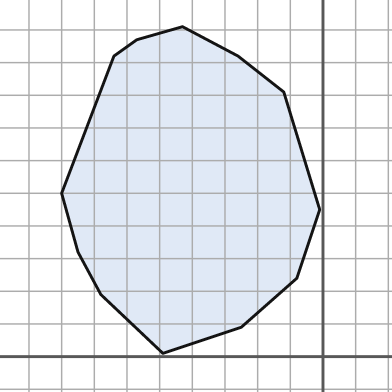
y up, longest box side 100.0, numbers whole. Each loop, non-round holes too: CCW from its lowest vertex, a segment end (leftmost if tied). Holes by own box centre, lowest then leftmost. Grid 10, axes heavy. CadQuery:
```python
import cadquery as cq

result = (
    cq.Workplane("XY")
    .moveTo(-49.0, 1.0)
    .lineTo(-25.0, 9.0)
    .lineTo(-8.0, 24.0)
    .lineTo(-1.0, 45.0)
    .lineTo(-12.0, 81.0)
    .lineTo(-26.0, 92.0)
    .lineTo(-43.0, 101.0)
    .lineTo(-57.0, 97.0)
    .lineTo(-64.0, 92.0)
    .lineTo(-80.0, 50.0)
    .lineTo(-75.0, 32.0)
    .lineTo(-68.0, 19.0)
    .close()
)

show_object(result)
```